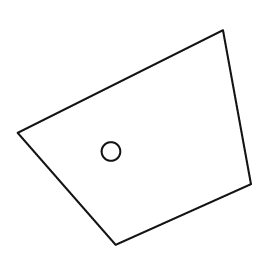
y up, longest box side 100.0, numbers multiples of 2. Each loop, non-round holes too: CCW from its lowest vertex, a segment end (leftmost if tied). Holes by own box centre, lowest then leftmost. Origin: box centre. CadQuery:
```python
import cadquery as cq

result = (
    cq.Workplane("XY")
    .moveTo(-8.0, -46.0)
    .lineTo(50.0, -20.0)
    .lineTo(38.0, 46.0)
    .lineTo(-50.0, 2.0)
    .close()
    .moveTo(-10.0, -6.0)
    .circle(4.0)
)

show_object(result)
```